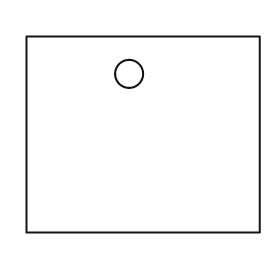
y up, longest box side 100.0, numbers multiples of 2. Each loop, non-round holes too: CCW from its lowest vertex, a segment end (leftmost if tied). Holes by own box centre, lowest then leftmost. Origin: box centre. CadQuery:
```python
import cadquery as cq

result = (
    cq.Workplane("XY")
    .moveTo(-50.0, -42.0)
    .lineTo(50.0, -42.0)
    .lineTo(50.0, 42.0)
    .lineTo(-50.0, 42.0)
    .close()
    .moveTo(-6.0, 26.0)
    .circle(6.0)
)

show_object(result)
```